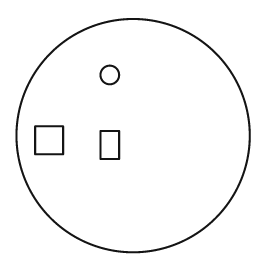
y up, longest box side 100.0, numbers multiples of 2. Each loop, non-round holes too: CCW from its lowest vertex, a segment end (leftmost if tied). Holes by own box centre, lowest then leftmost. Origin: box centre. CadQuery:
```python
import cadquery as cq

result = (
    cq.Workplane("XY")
    .moveTo(0.0, 0.0)
    .circle(50.0)
    .moveTo(-14.0, -10.0)
    .lineTo(-6.0, -10.0)
    .lineTo(-6.0, 2.0)
    .lineTo(-14.0, 2.0)
    .close()
    .moveTo(-42.0, -8.0)
    .lineTo(-30.0, -8.0)
    .lineTo(-30.0, 4.0)
    .lineTo(-42.0, 4.0)
    .close()
    .moveTo(-10.0, 26.0)
    .circle(4.0)
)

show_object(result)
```